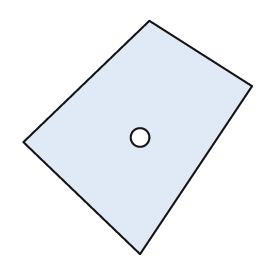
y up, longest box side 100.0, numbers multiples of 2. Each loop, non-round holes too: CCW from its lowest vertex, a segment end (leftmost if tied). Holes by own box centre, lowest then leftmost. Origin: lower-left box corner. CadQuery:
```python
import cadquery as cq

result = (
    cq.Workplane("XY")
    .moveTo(50.0, 0.0)
    .lineTo(98.0, 72.0)
    .lineTo(54.0, 100.0)
    .lineTo(0.0, 48.0)
    .close()
    .moveTo(50.0, 50.0)
    .circle(4.0)
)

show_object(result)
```